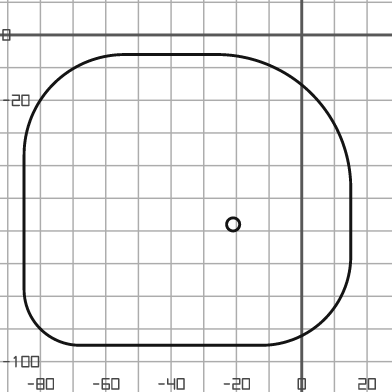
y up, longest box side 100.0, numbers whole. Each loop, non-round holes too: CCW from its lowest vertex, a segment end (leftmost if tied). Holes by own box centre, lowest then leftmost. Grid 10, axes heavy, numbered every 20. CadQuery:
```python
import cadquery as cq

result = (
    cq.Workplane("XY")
    .moveTo(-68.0, -95.0)
    .lineTo(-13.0, -95.0)
    .threePointArc((7.0, -87.0), (15.0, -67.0))
    .lineTo(15.0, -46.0)
    .threePointArc((3.0, -18.0), (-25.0, -6.0))
    .lineTo(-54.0, -6.0)
    .threePointArc((-76.0, -15.0), (-85.0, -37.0))
    .lineTo(-85.0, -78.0)
    .threePointArc((-80.0, -90.0), (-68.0, -95.0))
    .close()
    .moveTo(-21.0, -58.0)
    .circle(2.0)
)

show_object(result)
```